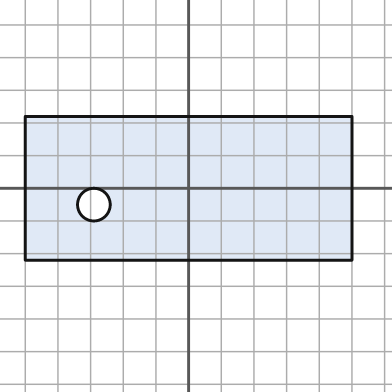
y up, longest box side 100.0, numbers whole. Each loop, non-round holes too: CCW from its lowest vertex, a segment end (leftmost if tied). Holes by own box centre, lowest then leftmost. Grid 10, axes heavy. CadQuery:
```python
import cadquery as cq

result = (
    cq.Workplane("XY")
    .moveTo(-50.0, -22.0)
    .lineTo(50.0, -22.0)
    .lineTo(50.0, 22.0)
    .lineTo(-50.0, 22.0)
    .close()
    .moveTo(-29.0, -5.0)
    .circle(5.0)
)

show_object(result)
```